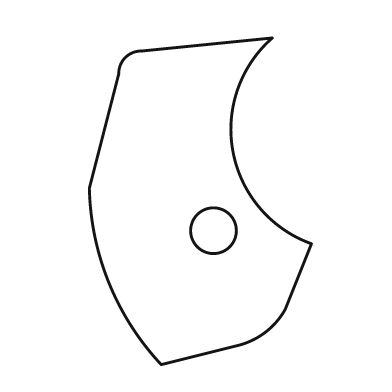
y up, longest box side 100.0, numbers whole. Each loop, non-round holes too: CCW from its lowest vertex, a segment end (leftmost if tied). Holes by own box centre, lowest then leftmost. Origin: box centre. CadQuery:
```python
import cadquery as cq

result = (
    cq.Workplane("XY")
    .moveTo(-12.0, -50.0)
    .lineTo(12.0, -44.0)
    .threePointArc((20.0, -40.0), (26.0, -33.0))
    .lineTo(34.0, -13.0)
    .threePointArc((10.0, 15.0), (22.0, 50.0))
    .lineTo(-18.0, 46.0)
    .threePointArc((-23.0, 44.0), (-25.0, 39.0))
    .lineTo(-34.0, 4.0)
    .threePointArc((-28.0, -25.0), (-12.0, -50.0))
    .close()
    .moveTo(4.0, -9.0)
    .circle(7.0)
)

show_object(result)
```